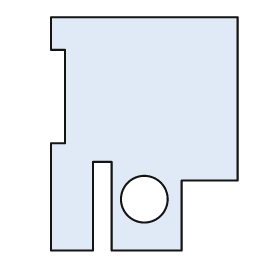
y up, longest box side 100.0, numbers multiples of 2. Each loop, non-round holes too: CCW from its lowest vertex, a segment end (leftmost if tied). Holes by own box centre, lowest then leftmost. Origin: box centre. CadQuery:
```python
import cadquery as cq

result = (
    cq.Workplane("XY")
    .moveTo(-40.0, -50.0)
    .lineTo(-22.0, -50.0)
    .lineTo(-22.0, -12.0)
    .lineTo(-14.0, -12.0)
    .lineTo(-14.0, -50.0)
    .lineTo(16.0, -50.0)
    .lineTo(16.0, -20.0)
    .lineTo(40.0, -20.0)
    .lineTo(40.0, 50.0)
    .lineTo(-40.0, 50.0)
    .lineTo(-40.0, 36.0)
    .lineTo(-34.0, 36.0)
    .lineTo(-34.0, -4.0)
    .lineTo(-40.0, -4.0)
    .close()
    .moveTo(0.0, -28.0)
    .circle(10.0)
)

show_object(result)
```